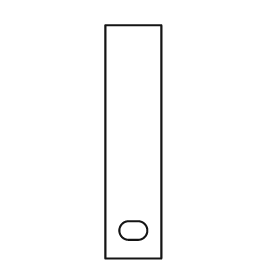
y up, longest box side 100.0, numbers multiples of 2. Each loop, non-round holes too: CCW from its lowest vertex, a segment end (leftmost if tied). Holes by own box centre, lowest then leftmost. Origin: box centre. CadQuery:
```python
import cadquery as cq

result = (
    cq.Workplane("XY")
    .moveTo(-12.0, -50.0)
    .lineTo(12.0, -50.0)
    .lineTo(12.0, 50.0)
    .lineTo(-12.0, 50.0)
    .close()
    .moveTo(-2.0, -42.0)
    .lineTo(2.0, -42.0)
    .threePointArc((6.0, -38.0), (2.0, -34.0))
    .lineTo(-2.0, -34.0)
    .threePointArc((-6.0, -38.0), (-2.0, -42.0))
    .close()
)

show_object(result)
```